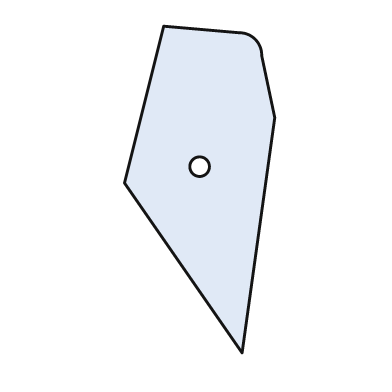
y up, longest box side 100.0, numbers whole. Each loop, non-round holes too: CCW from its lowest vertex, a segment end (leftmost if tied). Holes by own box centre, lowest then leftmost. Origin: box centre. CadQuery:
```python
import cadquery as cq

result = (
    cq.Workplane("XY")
    .moveTo(13.0, -50.0)
    .lineTo(23.0, 22.0)
    .lineTo(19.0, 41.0)
    .threePointArc((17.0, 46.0), (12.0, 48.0))
    .lineTo(-11.0, 50.0)
    .lineTo(-23.0, 2.0)
    .close()
    .moveTo(0.0, 7.0)
    .circle(3.0)
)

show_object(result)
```